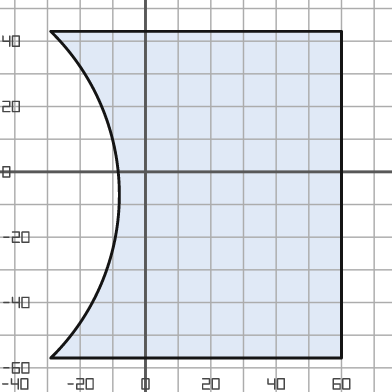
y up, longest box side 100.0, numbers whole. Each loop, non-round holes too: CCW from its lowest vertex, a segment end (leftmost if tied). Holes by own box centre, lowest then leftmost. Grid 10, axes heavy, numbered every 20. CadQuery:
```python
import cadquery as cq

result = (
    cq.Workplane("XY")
    .moveTo(-29.0, -57.0)
    .lineTo(60.0, -57.0)
    .lineTo(60.0, 43.0)
    .lineTo(-29.0, 43.0)
    .threePointArc((-8.0, -7.0), (-29.0, -57.0))
    .close()
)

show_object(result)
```